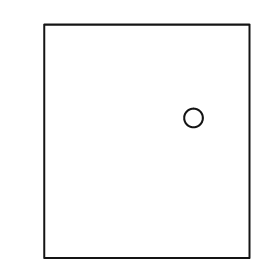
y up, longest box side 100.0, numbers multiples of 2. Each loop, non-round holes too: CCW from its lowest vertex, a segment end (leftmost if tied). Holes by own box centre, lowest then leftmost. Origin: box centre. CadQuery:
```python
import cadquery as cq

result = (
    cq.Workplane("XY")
    .moveTo(-44.0, -50.0)
    .lineTo(44.0, -50.0)
    .lineTo(44.0, 50.0)
    .lineTo(-44.0, 50.0)
    .close()
    .moveTo(20.0, 10.0)
    .circle(4.0)
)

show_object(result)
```